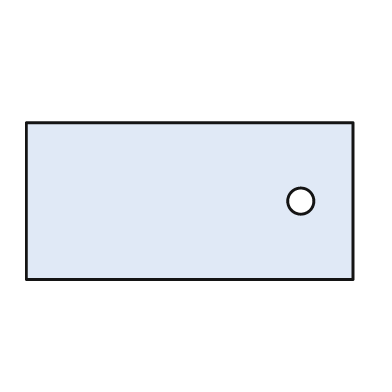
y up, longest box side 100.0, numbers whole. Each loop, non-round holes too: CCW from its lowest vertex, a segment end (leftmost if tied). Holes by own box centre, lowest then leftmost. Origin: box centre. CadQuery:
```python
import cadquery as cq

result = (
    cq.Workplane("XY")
    .moveTo(-50.0, -24.0)
    .lineTo(50.0, -24.0)
    .lineTo(50.0, 24.0)
    .lineTo(-50.0, 24.0)
    .close()
    .moveTo(34.0, 0.0)
    .circle(4.0)
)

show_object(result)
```